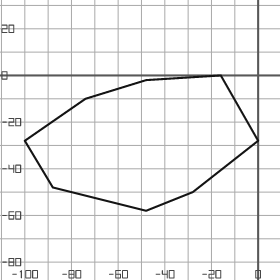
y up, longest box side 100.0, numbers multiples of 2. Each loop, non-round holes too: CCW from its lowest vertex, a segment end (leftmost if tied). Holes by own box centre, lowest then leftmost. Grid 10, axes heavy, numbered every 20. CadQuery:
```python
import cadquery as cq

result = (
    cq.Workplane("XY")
    .moveTo(-48.0, -58.0)
    .lineTo(-28.0, -50.0)
    .lineTo(0.0, -28.0)
    .lineTo(-16.0, 0.0)
    .lineTo(-48.0, -2.0)
    .lineTo(-74.0, -10.0)
    .lineTo(-100.0, -28.0)
    .lineTo(-88.0, -48.0)
    .close()
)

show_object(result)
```